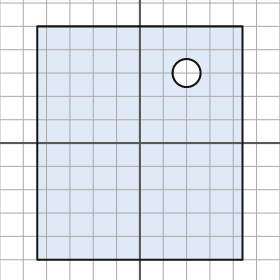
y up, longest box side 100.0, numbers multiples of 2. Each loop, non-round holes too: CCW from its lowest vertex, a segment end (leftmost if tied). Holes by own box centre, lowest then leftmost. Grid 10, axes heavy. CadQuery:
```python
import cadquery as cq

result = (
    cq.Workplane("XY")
    .moveTo(-44.0, -50.0)
    .lineTo(44.0, -50.0)
    .lineTo(44.0, 50.0)
    .lineTo(-44.0, 50.0)
    .close()
    .moveTo(20.0, 30.0)
    .circle(6.0)
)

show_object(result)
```